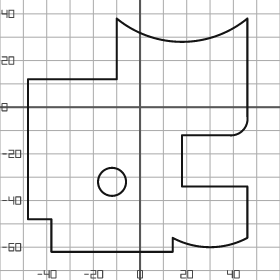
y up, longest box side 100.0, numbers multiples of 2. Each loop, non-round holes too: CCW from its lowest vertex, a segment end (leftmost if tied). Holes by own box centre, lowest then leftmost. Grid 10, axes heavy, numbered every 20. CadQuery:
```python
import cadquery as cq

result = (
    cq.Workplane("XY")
    .moveTo(-38.0, -62.0)
    .lineTo(14.0, -62.0)
    .lineTo(14.0, -56.0)
    .threePointArc((30.0, -60.0), (46.0, -56.0))
    .lineTo(46.0, -34.0)
    .lineTo(18.0, -34.0)
    .lineTo(18.0, -12.0)
    .lineTo(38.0, -12.0)
    .threePointArc((44.0, -10.0), (46.0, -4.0))
    .lineTo(46.0, 38.0)
    .threePointArc((18.0, 28.0), (-10.0, 38.0))
    .lineTo(-10.0, 12.0)
    .lineTo(-48.0, 12.0)
    .lineTo(-48.0, -48.0)
    .lineTo(-38.0, -48.0)
    .close()
    .moveTo(-12.0, -32.0)
    .circle(6.0)
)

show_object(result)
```